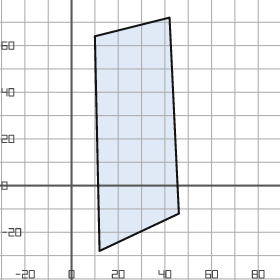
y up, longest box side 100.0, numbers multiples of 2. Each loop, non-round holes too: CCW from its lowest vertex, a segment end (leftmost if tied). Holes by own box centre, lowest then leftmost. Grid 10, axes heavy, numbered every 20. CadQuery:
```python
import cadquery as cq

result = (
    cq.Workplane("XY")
    .moveTo(12.0, -28.0)
    .lineTo(46.0, -12.0)
    .lineTo(42.0, 72.0)
    .lineTo(10.0, 64.0)
    .close()
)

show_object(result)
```